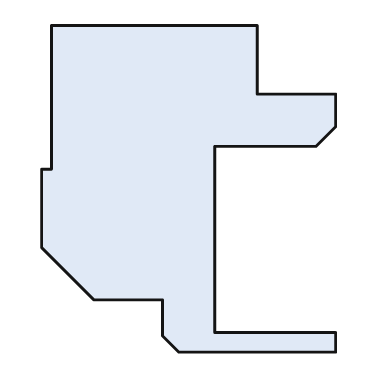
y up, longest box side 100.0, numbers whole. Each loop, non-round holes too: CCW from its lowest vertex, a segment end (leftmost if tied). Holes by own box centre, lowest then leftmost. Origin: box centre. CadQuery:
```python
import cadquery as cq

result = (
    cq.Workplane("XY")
    .moveTo(-3.0, -50.0)
    .lineTo(45.0, -50.0)
    .lineTo(45.0, -44.0)
    .lineTo(8.0, -44.0)
    .lineTo(8.0, 13.0)
    .lineTo(39.0, 13.0)
    .lineTo(45.0, 19.0)
    .lineTo(45.0, 29.0)
    .lineTo(21.0, 29.0)
    .lineTo(21.0, 50.0)
    .lineTo(-42.0, 50.0)
    .lineTo(-42.0, 6.0)
    .lineTo(-45.0, 6.0)
    .lineTo(-45.0, -18.0)
    .lineTo(-29.0, -34.0)
    .lineTo(-8.0, -34.0)
    .lineTo(-8.0, -45.0)
    .close()
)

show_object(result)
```